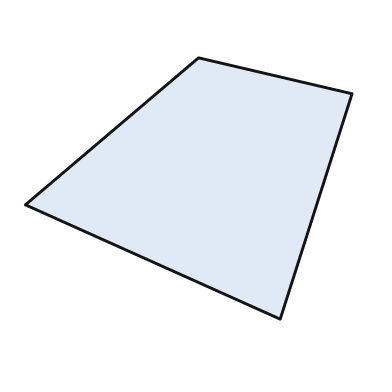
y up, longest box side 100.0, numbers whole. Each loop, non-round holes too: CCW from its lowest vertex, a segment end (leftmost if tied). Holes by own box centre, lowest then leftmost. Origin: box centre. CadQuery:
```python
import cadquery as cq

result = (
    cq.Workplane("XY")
    .moveTo(28.0, -40.0)
    .lineTo(50.0, 29.0)
    .lineTo(3.0, 40.0)
    .lineTo(-50.0, -5.0)
    .close()
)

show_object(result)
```